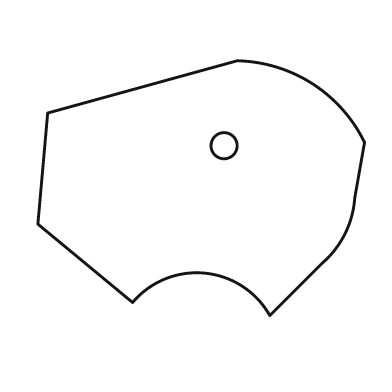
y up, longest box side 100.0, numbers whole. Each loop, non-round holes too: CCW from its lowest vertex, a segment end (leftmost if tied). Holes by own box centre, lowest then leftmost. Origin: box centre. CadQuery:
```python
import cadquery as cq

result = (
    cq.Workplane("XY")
    .moveTo(21.0, -39.0)
    .lineTo(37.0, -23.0)
    .threePointArc((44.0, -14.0), (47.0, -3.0))
    .lineTo(50.0, 14.0)
    .threePointArc((34.0, 32.0), (11.0, 39.0))
    .lineTo(-47.0, 23.0)
    .lineTo(-50.0, -11.0)
    .lineTo(-21.0, -35.0)
    .threePointArc((1.0, -26.0), (21.0, -39.0))
    .close()
    .moveTo(7.0, 13.0)
    .circle(4.0)
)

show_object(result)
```